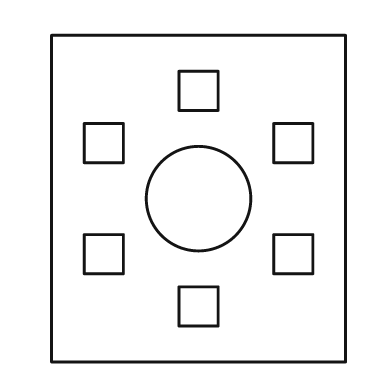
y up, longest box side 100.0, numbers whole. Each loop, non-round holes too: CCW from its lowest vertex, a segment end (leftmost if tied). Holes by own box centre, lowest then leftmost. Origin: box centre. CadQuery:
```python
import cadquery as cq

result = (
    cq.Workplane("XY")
    .moveTo(-45.0, -50.0)
    .lineTo(45.0, -50.0)
    .lineTo(45.0, 50.0)
    .lineTo(-45.0, 50.0)
    .close()
    .moveTo(-6.0, -39.0)
    .lineTo(6.0, -39.0)
    .lineTo(6.0, -27.0)
    .lineTo(-6.0, -27.0)
    .close()
    .moveTo(-35.0, -23.0)
    .lineTo(-23.0, -23.0)
    .lineTo(-23.0, -11.0)
    .lineTo(-35.0, -11.0)
    .close()
    .moveTo(23.0, -23.0)
    .lineTo(35.0, -23.0)
    .lineTo(35.0, -11.0)
    .lineTo(23.0, -11.0)
    .close()
    .moveTo(0.0, 0.0)
    .circle(16.0)
    .moveTo(-35.0, 11.0)
    .lineTo(-23.0, 11.0)
    .lineTo(-23.0, 23.0)
    .lineTo(-35.0, 23.0)
    .close()
    .moveTo(23.0, 11.0)
    .lineTo(35.0, 11.0)
    .lineTo(35.0, 23.0)
    .lineTo(23.0, 23.0)
    .close()
    .moveTo(-6.0, 27.0)
    .lineTo(6.0, 27.0)
    .lineTo(6.0, 39.0)
    .lineTo(-6.0, 39.0)
    .close()
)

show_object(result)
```